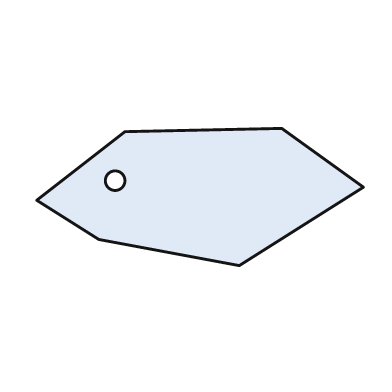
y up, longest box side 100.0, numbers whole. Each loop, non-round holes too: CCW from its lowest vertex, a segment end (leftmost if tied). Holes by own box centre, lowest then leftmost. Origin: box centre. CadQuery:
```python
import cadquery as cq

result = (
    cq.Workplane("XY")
    .moveTo(12.0, -21.0)
    .lineTo(50.0, 3.0)
    .lineTo(25.0, 21.0)
    .lineTo(-23.0, 20.0)
    .lineTo(-50.0, -1.0)
    .lineTo(-31.0, -13.0)
    .close()
    .moveTo(-26.0, 5.0)
    .circle(3.0)
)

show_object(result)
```